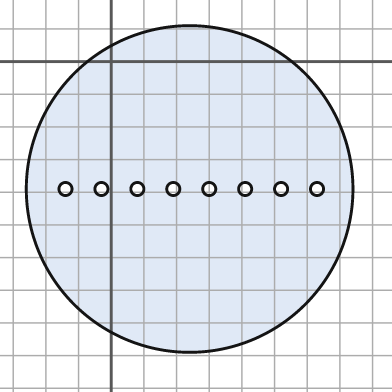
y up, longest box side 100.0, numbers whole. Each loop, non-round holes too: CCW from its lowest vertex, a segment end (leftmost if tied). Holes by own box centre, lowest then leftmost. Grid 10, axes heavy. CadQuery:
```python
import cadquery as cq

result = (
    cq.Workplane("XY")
    .moveTo(24.0, -39.0)
    .circle(50.0)
    .moveTo(-14.0, -39.0)
    .circle(2.0)
    .moveTo(-3.0, -39.0)
    .circle(2.0)
    .moveTo(8.0, -39.0)
    .circle(2.0)
    .moveTo(19.0, -39.0)
    .circle(2.0)
    .moveTo(30.0, -39.0)
    .circle(2.0)
    .moveTo(41.0, -39.0)
    .circle(2.0)
    .moveTo(52.0, -39.0)
    .circle(2.0)
    .moveTo(63.0, -39.0)
    .circle(2.0)
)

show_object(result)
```